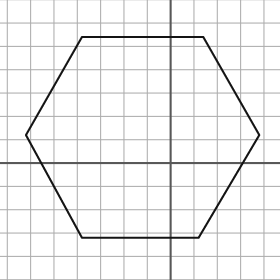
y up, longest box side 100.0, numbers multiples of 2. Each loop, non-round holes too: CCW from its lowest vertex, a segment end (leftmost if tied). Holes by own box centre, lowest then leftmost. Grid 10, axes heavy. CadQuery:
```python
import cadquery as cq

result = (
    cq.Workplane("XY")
    .moveTo(-38.0, -32.0)
    .lineTo(12.0, -32.0)
    .lineTo(38.0, 12.0)
    .lineTo(14.0, 54.0)
    .lineTo(-38.0, 54.0)
    .lineTo(-62.0, 12.0)
    .close()
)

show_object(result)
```